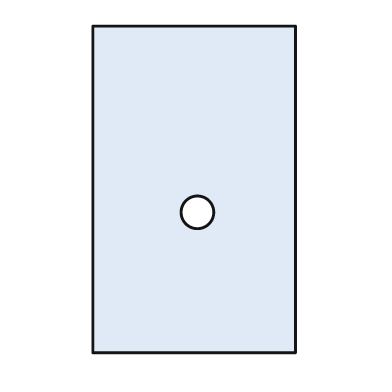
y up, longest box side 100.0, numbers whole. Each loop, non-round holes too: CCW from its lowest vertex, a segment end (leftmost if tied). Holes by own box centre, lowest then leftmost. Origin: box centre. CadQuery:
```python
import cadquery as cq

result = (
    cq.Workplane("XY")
    .moveTo(-31.0, -50.0)
    .lineTo(31.0, -50.0)
    .lineTo(31.0, 50.0)
    .lineTo(-31.0, 50.0)
    .close()
    .moveTo(1.0, -7.0)
    .circle(5.0)
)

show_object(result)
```